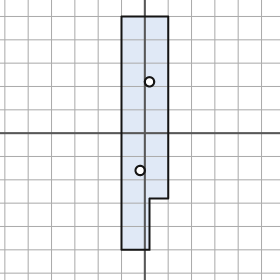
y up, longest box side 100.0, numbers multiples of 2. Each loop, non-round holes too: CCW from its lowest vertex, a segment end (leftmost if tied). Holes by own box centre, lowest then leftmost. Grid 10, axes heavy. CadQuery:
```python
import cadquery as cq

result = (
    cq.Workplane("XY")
    .moveTo(-10.0, -50.0)
    .lineTo(2.0, -50.0)
    .lineTo(2.0, -28.0)
    .lineTo(10.0, -28.0)
    .lineTo(10.0, 50.0)
    .lineTo(-10.0, 50.0)
    .close()
    .moveTo(-2.0, -16.0)
    .circle(2.0)
    .moveTo(2.0, 22.0)
    .circle(2.0)
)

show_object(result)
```